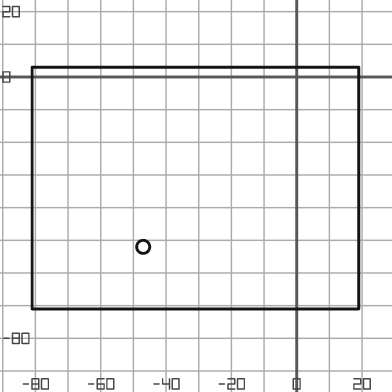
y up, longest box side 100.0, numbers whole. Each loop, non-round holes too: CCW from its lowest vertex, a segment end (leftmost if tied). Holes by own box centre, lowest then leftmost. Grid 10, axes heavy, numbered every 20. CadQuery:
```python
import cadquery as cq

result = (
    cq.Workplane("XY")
    .moveTo(-81.0, -71.0)
    .lineTo(19.0, -71.0)
    .lineTo(19.0, 3.0)
    .lineTo(-81.0, 3.0)
    .close()
    .moveTo(-47.0, -52.0)
    .circle(2.0)
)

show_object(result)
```